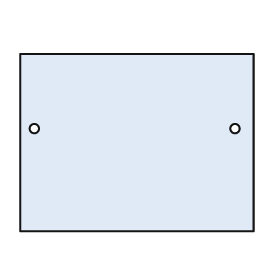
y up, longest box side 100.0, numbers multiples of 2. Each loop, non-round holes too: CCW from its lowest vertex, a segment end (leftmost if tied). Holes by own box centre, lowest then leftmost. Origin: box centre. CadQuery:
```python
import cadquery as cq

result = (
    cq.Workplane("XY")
    .moveTo(-50.0, -38.0)
    .lineTo(50.0, -38.0)
    .lineTo(50.0, 38.0)
    .lineTo(-50.0, 38.0)
    .close()
    .moveTo(-44.0, 6.0)
    .circle(2.0)
    .moveTo(42.0, 6.0)
    .circle(2.0)
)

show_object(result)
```